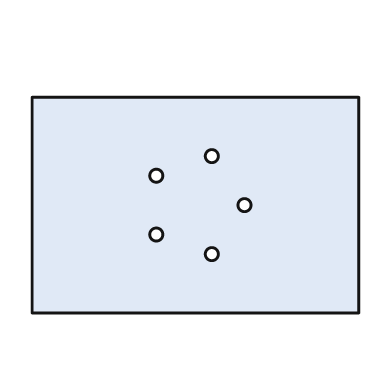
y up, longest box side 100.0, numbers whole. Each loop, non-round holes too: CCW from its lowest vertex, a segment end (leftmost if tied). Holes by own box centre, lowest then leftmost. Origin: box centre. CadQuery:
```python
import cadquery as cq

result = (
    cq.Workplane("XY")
    .moveTo(-50.0, -33.0)
    .lineTo(50.0, -33.0)
    .lineTo(50.0, 33.0)
    .lineTo(-50.0, 33.0)
    .close()
    .moveTo(5.0, -15.0)
    .circle(2.0)
    .moveTo(-12.0, -9.0)
    .circle(2.0)
    .moveTo(15.0, 0.0)
    .circle(2.0)
    .moveTo(-12.0, 9.0)
    .circle(2.0)
    .moveTo(5.0, 15.0)
    .circle(2.0)
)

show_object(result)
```